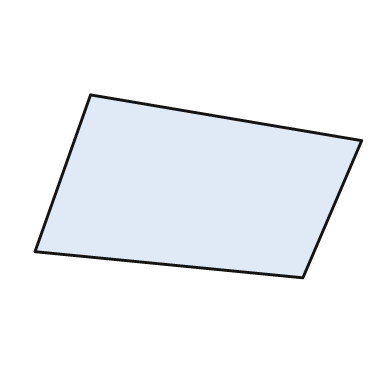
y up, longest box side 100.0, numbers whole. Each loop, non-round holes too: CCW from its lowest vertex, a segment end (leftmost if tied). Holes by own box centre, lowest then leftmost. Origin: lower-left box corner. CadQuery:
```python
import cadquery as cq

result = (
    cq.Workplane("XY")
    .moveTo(82.0, 0.0)
    .lineTo(100.0, 42.0)
    .lineTo(17.0, 56.0)
    .lineTo(0.0, 8.0)
    .close()
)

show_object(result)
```